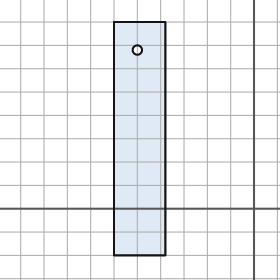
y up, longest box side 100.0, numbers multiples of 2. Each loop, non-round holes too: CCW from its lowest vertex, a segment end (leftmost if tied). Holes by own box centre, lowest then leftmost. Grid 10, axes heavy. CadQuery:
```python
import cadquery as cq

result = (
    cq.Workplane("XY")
    .moveTo(-60.0, -20.0)
    .lineTo(-38.0, -20.0)
    .lineTo(-38.0, 80.0)
    .lineTo(-60.0, 80.0)
    .close()
    .moveTo(-50.0, 68.0)
    .circle(2.0)
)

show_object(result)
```